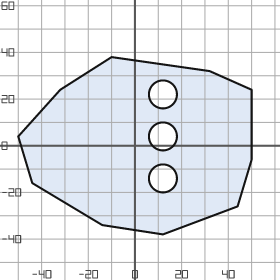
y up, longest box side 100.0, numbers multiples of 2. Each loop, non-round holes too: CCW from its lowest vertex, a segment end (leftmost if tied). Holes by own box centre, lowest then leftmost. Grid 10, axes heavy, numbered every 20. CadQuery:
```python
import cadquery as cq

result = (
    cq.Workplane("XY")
    .moveTo(12.0, -38.0)
    .lineTo(44.0, -26.0)
    .lineTo(50.0, -6.0)
    .lineTo(50.0, 24.0)
    .lineTo(32.0, 32.0)
    .lineTo(-10.0, 38.0)
    .lineTo(-32.0, 24.0)
    .lineTo(-50.0, 4.0)
    .lineTo(-44.0, -16.0)
    .lineTo(-14.0, -34.0)
    .close()
    .moveTo(12.0, -14.0)
    .circle(6.0)
    .moveTo(12.0, 4.0)
    .circle(6.0)
    .moveTo(12.0, 22.0)
    .circle(6.0)
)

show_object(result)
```